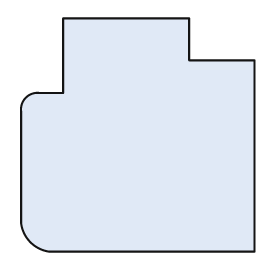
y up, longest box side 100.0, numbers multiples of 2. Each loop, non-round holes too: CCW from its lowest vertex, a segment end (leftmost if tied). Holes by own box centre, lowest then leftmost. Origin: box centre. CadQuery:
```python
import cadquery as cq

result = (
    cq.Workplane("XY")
    .moveTo(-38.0, -50.0)
    .lineTo(50.0, -50.0)
    .lineTo(50.0, 32.0)
    .lineTo(22.0, 32.0)
    .lineTo(22.0, 50.0)
    .lineTo(-32.0, 50.0)
    .lineTo(-32.0, 18.0)
    .lineTo(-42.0, 18.0)
    .threePointArc((-48.0, 16.0), (-50.0, 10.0))
    .lineTo(-50.0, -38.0)
    .threePointArc((-46.0, -46.0), (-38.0, -50.0))
    .close()
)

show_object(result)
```